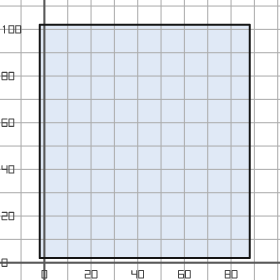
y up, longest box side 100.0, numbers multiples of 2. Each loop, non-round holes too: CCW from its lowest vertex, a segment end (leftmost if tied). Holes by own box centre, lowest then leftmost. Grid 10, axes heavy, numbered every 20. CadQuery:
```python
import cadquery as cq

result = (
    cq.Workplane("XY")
    .moveTo(-2.0, 2.0)
    .lineTo(88.0, 2.0)
    .lineTo(88.0, 102.0)
    .lineTo(-2.0, 102.0)
    .close()
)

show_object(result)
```